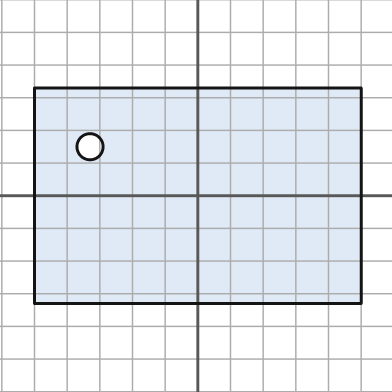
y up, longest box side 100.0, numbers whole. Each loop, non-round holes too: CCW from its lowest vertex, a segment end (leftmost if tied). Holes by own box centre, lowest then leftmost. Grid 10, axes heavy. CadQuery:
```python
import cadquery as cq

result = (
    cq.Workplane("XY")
    .moveTo(-50.0, -33.0)
    .lineTo(50.0, -33.0)
    .lineTo(50.0, 33.0)
    .lineTo(-50.0, 33.0)
    .close()
    .moveTo(-33.0, 15.0)
    .circle(4.0)
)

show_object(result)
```